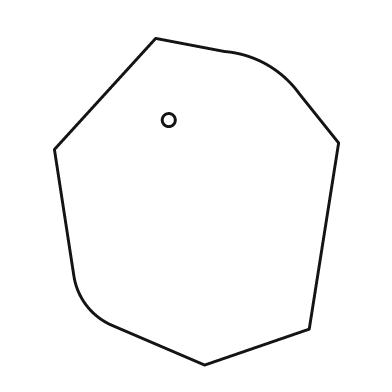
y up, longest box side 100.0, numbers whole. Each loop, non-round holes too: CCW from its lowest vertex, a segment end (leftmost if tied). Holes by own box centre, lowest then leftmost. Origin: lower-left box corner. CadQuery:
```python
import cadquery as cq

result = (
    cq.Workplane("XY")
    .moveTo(46.0, 0.0)
    .lineTo(78.0, 11.0)
    .lineTo(87.0, 68.0)
    .lineTo(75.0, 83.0)
    .threePointArc((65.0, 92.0), (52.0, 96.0))
    .lineTo(31.0, 100.0)
    .lineTo(0.0, 66.0)
    .lineTo(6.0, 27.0)
    .threePointArc((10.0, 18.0), (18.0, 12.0))
    .close()
    .moveTo(35.0, 75.0)
    .circle(2.0)
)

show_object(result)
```